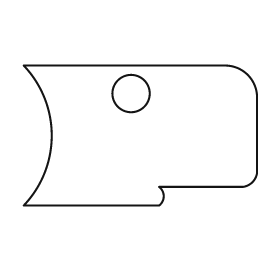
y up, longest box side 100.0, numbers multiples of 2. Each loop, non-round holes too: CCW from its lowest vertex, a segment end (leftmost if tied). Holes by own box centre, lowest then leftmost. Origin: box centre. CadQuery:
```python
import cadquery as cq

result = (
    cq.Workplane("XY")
    .moveTo(-50.0, -30.0)
    .lineTo(8.0, -30.0)
    .threePointArc((10.0, -26.0), (8.0, -22.0))
    .lineTo(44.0, -22.0)
    .threePointArc((48.0, -20.0), (50.0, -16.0))
    .lineTo(50.0, 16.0)
    .threePointArc((46.0, 26.0), (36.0, 30.0))
    .lineTo(-50.0, 30.0)
    .threePointArc((-38.0, 0.0), (-50.0, -30.0))
    .close()
    .moveTo(-4.0, 18.0)
    .circle(8.0)
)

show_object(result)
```